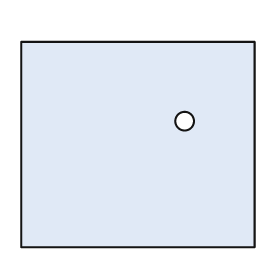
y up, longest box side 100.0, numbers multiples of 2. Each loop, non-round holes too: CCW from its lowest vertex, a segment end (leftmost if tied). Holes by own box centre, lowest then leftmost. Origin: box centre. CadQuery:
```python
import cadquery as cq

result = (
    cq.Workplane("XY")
    .moveTo(-50.0, -44.0)
    .lineTo(50.0, -44.0)
    .lineTo(50.0, 44.0)
    .lineTo(-50.0, 44.0)
    .close()
    .moveTo(20.0, 10.0)
    .circle(4.0)
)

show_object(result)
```